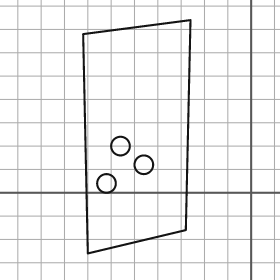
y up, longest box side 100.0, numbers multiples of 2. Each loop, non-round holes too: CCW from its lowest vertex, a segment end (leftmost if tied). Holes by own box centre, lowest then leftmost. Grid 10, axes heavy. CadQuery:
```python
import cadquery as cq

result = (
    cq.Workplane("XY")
    .moveTo(-70.0, -26.0)
    .lineTo(-28.0, -16.0)
    .lineTo(-26.0, 74.0)
    .lineTo(-72.0, 68.0)
    .close()
    .moveTo(-62.0, 4.0)
    .circle(4.0)
    .moveTo(-46.0, 12.0)
    .circle(4.0)
    .moveTo(-56.0, 20.0)
    .circle(4.0)
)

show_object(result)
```